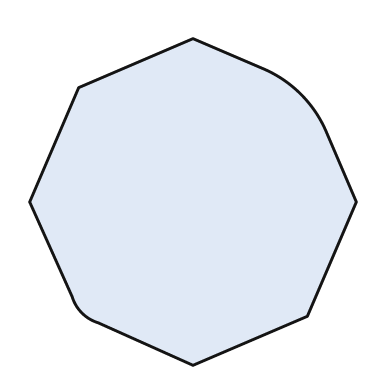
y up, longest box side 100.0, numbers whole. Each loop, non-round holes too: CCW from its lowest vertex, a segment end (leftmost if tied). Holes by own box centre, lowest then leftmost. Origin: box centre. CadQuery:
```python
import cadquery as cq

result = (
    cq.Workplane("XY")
    .moveTo(0.0, -50.0)
    .lineTo(35.0, -35.0)
    .lineTo(50.0, 0.0)
    .lineTo(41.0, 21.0)
    .threePointArc((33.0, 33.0), (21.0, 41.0))
    .lineTo(0.0, 50.0)
    .lineTo(-35.0, 35.0)
    .lineTo(-50.0, 0.0)
    .lineTo(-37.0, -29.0)
    .threePointArc((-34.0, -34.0), (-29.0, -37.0))
    .close()
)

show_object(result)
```